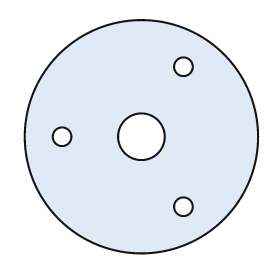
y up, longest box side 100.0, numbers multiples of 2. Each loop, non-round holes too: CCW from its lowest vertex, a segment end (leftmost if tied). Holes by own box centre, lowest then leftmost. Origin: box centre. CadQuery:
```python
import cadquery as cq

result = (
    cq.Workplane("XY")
    .moveTo(0.0, 0.0)
    .circle(50.0)
    .moveTo(18.0, -30.0)
    .circle(4.0)
    .moveTo(-34.0, 0.0)
    .circle(4.0)
    .moveTo(0.0, 0.0)
    .circle(10.0)
    .moveTo(18.0, 30.0)
    .circle(4.0)
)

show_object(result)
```